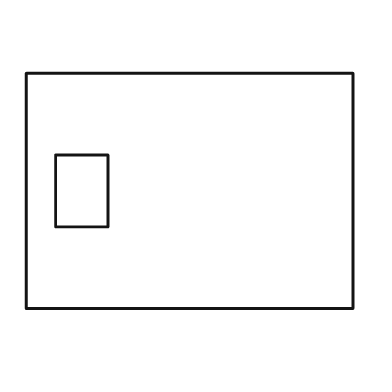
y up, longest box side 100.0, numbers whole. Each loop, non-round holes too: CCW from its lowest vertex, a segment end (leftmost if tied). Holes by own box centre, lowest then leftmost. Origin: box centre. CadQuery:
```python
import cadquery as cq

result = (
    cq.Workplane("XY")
    .moveTo(-50.0, -36.0)
    .lineTo(50.0, -36.0)
    .lineTo(50.0, 36.0)
    .lineTo(-50.0, 36.0)
    .close()
    .moveTo(-41.0, -11.0)
    .lineTo(-25.0, -11.0)
    .lineTo(-25.0, 11.0)
    .lineTo(-41.0, 11.0)
    .close()
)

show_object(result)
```